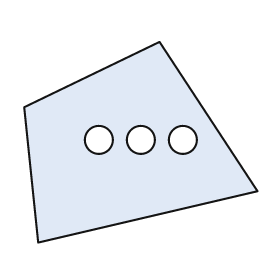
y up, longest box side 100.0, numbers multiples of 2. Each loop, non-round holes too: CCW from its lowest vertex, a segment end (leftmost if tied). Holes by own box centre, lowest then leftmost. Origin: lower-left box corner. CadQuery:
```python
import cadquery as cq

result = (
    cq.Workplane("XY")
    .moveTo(6.0, 0.0)
    .lineTo(100.0, 22.0)
    .lineTo(58.0, 86.0)
    .lineTo(0.0, 58.0)
    .close()
    .moveTo(32.0, 44.0)
    .circle(6.0)
    .moveTo(50.0, 44.0)
    .circle(6.0)
    .moveTo(68.0, 44.0)
    .circle(6.0)
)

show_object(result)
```